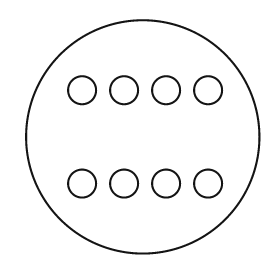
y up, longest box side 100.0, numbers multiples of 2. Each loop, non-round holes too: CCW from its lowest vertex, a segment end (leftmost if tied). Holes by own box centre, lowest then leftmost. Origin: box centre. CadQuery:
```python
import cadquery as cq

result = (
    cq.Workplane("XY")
    .moveTo(0.0, 0.0)
    .circle(50.0)
    .moveTo(-26.0, -20.0)
    .circle(6.0)
    .moveTo(-8.0, -20.0)
    .circle(6.0)
    .moveTo(10.0, -20.0)
    .circle(6.0)
    .moveTo(28.0, -20.0)
    .circle(6.0)
    .moveTo(-26.0, 20.0)
    .circle(6.0)
    .moveTo(-8.0, 20.0)
    .circle(6.0)
    .moveTo(10.0, 20.0)
    .circle(6.0)
    .moveTo(28.0, 20.0)
    .circle(6.0)
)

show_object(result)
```